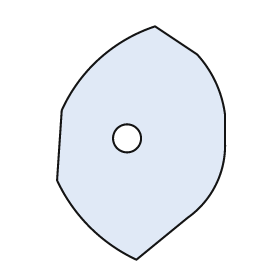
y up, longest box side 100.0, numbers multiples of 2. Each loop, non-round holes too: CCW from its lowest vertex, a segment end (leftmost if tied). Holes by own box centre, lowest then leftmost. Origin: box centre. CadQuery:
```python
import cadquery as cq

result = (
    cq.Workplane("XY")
    .moveTo(-2.0, -50.0)
    .lineTo(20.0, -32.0)
    .threePointArc((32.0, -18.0), (36.0, 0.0))
    .lineTo(36.0, 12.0)
    .threePointArc((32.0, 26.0), (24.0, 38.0))
    .lineTo(6.0, 50.0)
    .threePointArc((-18.0, 36.0), (-34.0, 14.0))
    .lineTo(-36.0, -16.0)
    .threePointArc((-22.0, -36.0), (-2.0, -50.0))
    .close()
    .moveTo(-6.0, 2.0)
    .circle(6.0)
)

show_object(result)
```